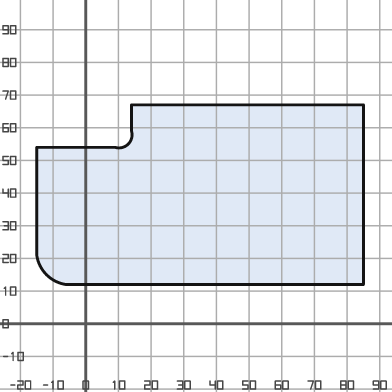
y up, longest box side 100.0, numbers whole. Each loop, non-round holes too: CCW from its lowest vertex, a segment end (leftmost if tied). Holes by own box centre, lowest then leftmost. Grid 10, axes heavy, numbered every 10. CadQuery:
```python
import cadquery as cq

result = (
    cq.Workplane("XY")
    .moveTo(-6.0, 12.0)
    .lineTo(85.0, 12.0)
    .lineTo(85.0, 67.0)
    .lineTo(14.0, 67.0)
    .lineTo(14.0, 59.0)
    .threePointArc((13.0, 55.0), (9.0, 54.0))
    .lineTo(-15.0, 54.0)
    .lineTo(-15.0, 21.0)
    .threePointArc((-12.0, 15.0), (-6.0, 12.0))
    .close()
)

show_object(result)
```